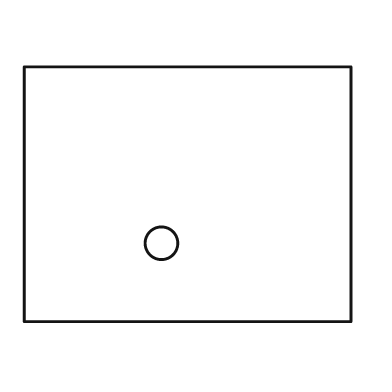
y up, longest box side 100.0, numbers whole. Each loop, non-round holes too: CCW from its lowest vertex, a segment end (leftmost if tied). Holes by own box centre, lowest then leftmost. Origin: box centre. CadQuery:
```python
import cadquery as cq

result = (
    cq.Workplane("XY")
    .moveTo(-50.0, -39.0)
    .lineTo(50.0, -39.0)
    .lineTo(50.0, 39.0)
    .lineTo(-50.0, 39.0)
    .close()
    .moveTo(-8.0, -15.0)
    .circle(5.0)
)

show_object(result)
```